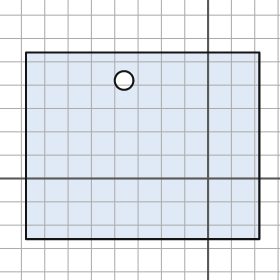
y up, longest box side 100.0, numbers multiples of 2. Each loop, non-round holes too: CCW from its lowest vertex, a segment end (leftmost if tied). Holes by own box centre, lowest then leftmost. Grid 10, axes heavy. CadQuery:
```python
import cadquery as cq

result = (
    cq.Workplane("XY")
    .moveTo(-78.0, -26.0)
    .lineTo(22.0, -26.0)
    .lineTo(22.0, 54.0)
    .lineTo(-78.0, 54.0)
    .close()
    .moveTo(-36.0, 42.0)
    .circle(4.0)
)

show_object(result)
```